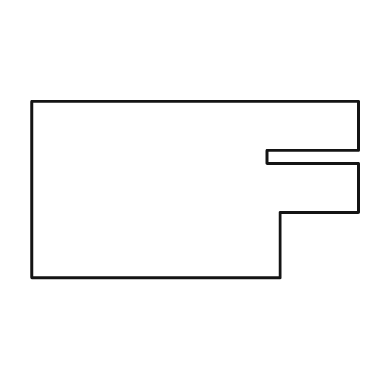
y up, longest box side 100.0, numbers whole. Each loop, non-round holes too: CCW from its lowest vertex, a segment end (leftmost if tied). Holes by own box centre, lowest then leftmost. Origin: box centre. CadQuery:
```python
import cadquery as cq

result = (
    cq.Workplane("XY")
    .moveTo(-50.0, -27.0)
    .lineTo(26.0, -27.0)
    .lineTo(26.0, -7.0)
    .lineTo(50.0, -7.0)
    .lineTo(50.0, 8.0)
    .lineTo(22.0, 8.0)
    .lineTo(22.0, 12.0)
    .lineTo(50.0, 12.0)
    .lineTo(50.0, 27.0)
    .lineTo(-50.0, 27.0)
    .close()
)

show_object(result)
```